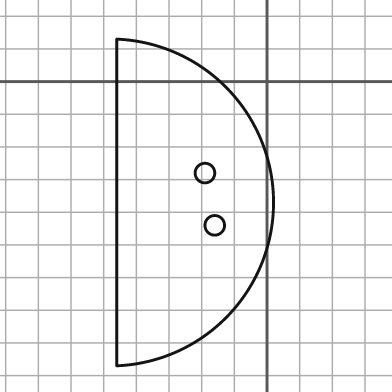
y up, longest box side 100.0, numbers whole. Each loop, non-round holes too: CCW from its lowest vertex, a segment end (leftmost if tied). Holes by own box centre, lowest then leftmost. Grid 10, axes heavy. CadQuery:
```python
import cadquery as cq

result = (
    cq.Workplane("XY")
    .moveTo(-46.0, -87.0)
    .threePointArc((2.0, -37.0), (-46.0, 13.0))
    .close()
    .moveTo(-16.0, -44.0)
    .circle(3.0)
    .moveTo(-19.0, -28.0)
    .circle(3.0)
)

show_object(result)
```